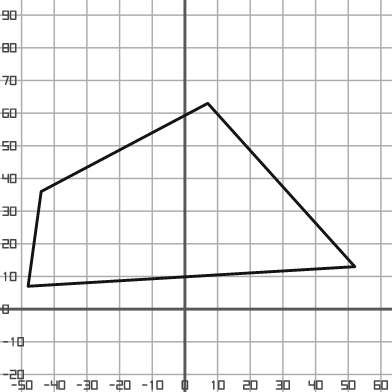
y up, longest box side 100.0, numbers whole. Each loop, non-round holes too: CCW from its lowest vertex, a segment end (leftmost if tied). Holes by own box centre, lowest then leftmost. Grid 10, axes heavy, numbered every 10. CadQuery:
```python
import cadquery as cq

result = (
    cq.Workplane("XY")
    .moveTo(-48.0, 7.0)
    .lineTo(52.0, 13.0)
    .lineTo(7.0, 63.0)
    .lineTo(-44.0, 36.0)
    .close()
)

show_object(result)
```